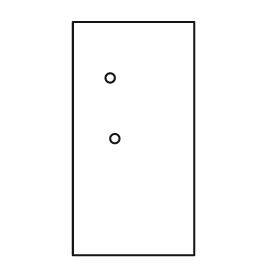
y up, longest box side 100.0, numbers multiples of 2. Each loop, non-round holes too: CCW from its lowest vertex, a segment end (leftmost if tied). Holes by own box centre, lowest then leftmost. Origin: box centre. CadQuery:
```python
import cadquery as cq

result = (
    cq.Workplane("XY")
    .moveTo(-26.0, -50.0)
    .lineTo(26.0, -50.0)
    .lineTo(26.0, 50.0)
    .lineTo(-26.0, 50.0)
    .close()
    .moveTo(-8.0, 0.0)
    .circle(2.0)
    .moveTo(-10.0, 26.0)
    .circle(2.0)
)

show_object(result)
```